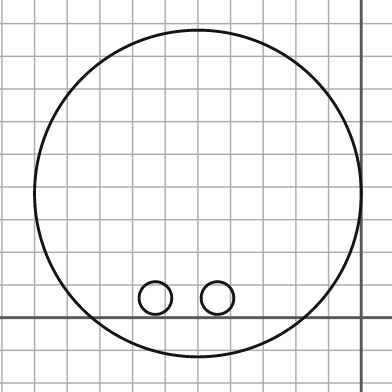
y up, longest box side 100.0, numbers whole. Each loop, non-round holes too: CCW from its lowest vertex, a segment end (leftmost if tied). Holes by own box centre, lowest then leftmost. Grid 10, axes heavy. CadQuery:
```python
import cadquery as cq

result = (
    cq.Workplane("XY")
    .moveTo(-50.0, 38.0)
    .circle(50.0)
    .moveTo(-63.0, 6.0)
    .circle(5.0)
    .moveTo(-44.0, 6.0)
    .circle(5.0)
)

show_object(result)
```